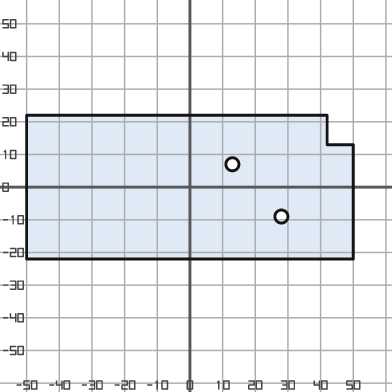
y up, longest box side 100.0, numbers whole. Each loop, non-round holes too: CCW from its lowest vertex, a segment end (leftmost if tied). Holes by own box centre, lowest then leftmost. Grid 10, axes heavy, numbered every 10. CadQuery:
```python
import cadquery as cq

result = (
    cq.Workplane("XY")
    .moveTo(-50.0, -22.0)
    .lineTo(50.0, -22.0)
    .lineTo(50.0, 13.0)
    .lineTo(42.0, 13.0)
    .lineTo(42.0, 22.0)
    .lineTo(-50.0, 22.0)
    .close()
    .moveTo(28.0, -9.0)
    .circle(2.0)
    .moveTo(13.0, 7.0)
    .circle(2.0)
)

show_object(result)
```